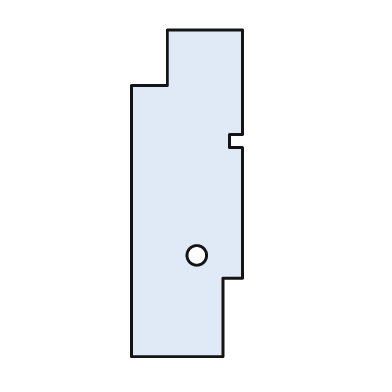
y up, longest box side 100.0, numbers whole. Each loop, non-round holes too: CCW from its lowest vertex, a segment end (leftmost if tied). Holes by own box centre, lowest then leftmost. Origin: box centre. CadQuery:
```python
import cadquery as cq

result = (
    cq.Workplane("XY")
    .moveTo(-17.0, -50.0)
    .lineTo(11.0, -50.0)
    .lineTo(11.0, -26.0)
    .lineTo(17.0, -26.0)
    .lineTo(17.0, 14.0)
    .lineTo(13.0, 14.0)
    .lineTo(13.0, 18.0)
    .lineTo(17.0, 18.0)
    .lineTo(17.0, 50.0)
    .lineTo(-6.0, 50.0)
    .lineTo(-6.0, 33.0)
    .lineTo(-17.0, 33.0)
    .close()
    .moveTo(3.0, -19.0)
    .circle(3.0)
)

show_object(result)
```